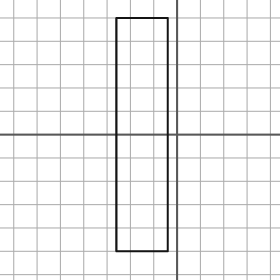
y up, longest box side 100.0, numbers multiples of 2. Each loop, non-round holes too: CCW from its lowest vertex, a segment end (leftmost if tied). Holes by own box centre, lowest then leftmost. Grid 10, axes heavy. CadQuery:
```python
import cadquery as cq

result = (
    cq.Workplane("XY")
    .moveTo(-26.0, -50.0)
    .lineTo(-4.0, -50.0)
    .lineTo(-4.0, 50.0)
    .lineTo(-26.0, 50.0)
    .close()
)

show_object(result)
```